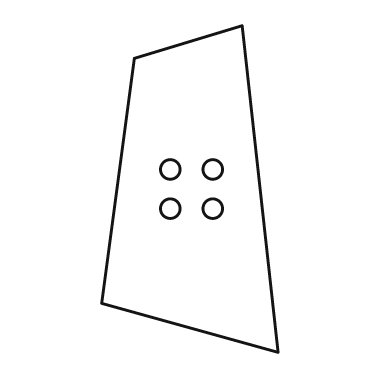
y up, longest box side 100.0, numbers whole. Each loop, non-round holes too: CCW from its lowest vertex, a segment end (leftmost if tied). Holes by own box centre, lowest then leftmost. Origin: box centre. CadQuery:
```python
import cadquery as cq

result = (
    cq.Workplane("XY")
    .moveTo(27.0, -50.0)
    .lineTo(16.0, 50.0)
    .lineTo(-17.0, 40.0)
    .lineTo(-27.0, -35.0)
    .close()
    .moveTo(-6.0, -6.0)
    .circle(3.0)
    .moveTo(7.0, -6.0)
    .circle(3.0)
    .moveTo(-6.0, 6.0)
    .circle(3.0)
    .moveTo(7.0, 6.0)
    .circle(3.0)
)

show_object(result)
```